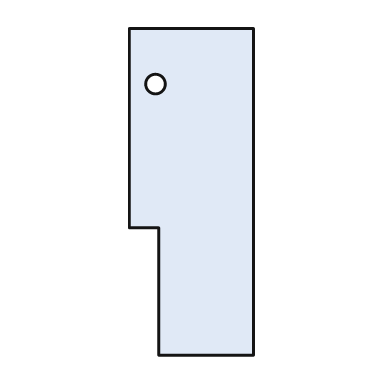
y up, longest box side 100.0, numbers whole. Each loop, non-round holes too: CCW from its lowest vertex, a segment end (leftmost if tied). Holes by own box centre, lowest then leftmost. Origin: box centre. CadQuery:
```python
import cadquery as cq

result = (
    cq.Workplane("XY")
    .moveTo(-10.0, -50.0)
    .lineTo(19.0, -50.0)
    .lineTo(19.0, 50.0)
    .lineTo(-19.0, 50.0)
    .lineTo(-19.0, -11.0)
    .lineTo(-10.0, -11.0)
    .close()
    .moveTo(-11.0, 33.0)
    .circle(3.0)
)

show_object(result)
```